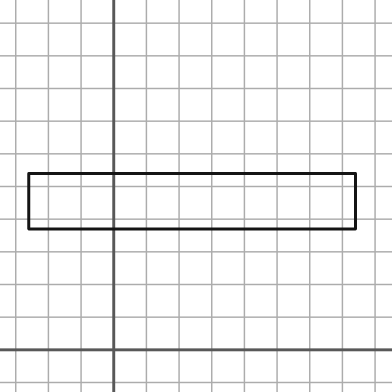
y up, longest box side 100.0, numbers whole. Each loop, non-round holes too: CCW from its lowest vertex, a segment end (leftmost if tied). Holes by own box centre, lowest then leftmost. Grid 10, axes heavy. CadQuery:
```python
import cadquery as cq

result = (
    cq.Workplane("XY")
    .moveTo(-26.0, 37.0)
    .lineTo(74.0, 37.0)
    .lineTo(74.0, 54.0)
    .lineTo(-26.0, 54.0)
    .close()
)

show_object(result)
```